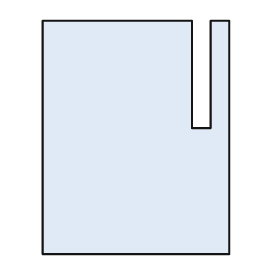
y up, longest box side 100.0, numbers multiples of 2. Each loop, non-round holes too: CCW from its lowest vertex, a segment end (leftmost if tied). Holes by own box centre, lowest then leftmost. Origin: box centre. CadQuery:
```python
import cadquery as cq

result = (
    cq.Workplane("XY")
    .moveTo(-40.0, -50.0)
    .lineTo(40.0, -50.0)
    .lineTo(40.0, 50.0)
    .lineTo(32.0, 50.0)
    .lineTo(32.0, 4.0)
    .lineTo(24.0, 4.0)
    .lineTo(24.0, 50.0)
    .lineTo(-40.0, 50.0)
    .close()
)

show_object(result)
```